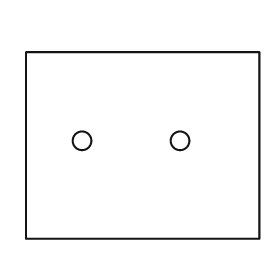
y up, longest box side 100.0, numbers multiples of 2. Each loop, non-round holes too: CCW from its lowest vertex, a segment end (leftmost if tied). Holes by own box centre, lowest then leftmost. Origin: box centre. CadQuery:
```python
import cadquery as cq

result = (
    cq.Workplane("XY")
    .moveTo(-50.0, -40.0)
    .lineTo(50.0, -40.0)
    .lineTo(50.0, 40.0)
    .lineTo(-50.0, 40.0)
    .close()
    .moveTo(-26.0, 2.0)
    .circle(4.0)
    .moveTo(16.0, 2.0)
    .circle(4.0)
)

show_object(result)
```